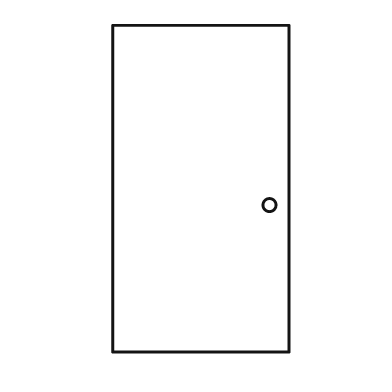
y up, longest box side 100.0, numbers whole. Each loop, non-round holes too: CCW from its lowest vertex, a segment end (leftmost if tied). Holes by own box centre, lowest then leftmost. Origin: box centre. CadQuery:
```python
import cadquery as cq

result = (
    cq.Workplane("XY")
    .moveTo(-27.0, -50.0)
    .lineTo(27.0, -50.0)
    .lineTo(27.0, 50.0)
    .lineTo(-27.0, 50.0)
    .close()
    .moveTo(21.0, -5.0)
    .circle(2.0)
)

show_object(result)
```